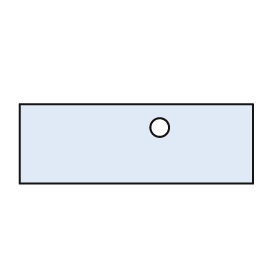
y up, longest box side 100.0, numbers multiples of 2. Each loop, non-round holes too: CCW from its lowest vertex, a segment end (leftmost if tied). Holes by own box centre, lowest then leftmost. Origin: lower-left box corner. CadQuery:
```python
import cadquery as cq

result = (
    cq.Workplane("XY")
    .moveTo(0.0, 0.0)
    .lineTo(100.0, 0.0)
    .lineTo(100.0, 34.0)
    .lineTo(0.0, 34.0)
    .close()
    .moveTo(60.0, 24.0)
    .circle(4.0)
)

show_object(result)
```